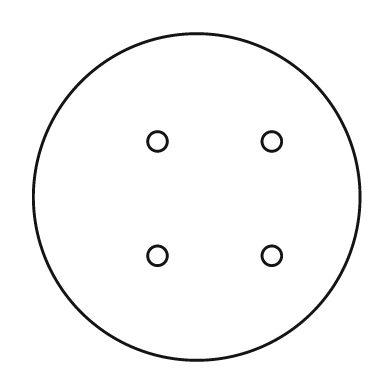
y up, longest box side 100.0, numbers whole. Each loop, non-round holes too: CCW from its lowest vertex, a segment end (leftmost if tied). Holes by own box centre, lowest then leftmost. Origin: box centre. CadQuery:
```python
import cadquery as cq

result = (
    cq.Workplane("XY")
    .moveTo(0.0, 0.0)
    .circle(50.0)
    .moveTo(-12.0, -18.0)
    .circle(3.0)
    .moveTo(23.0, -18.0)
    .circle(3.0)
    .moveTo(-12.0, 17.0)
    .circle(3.0)
    .moveTo(23.0, 17.0)
    .circle(3.0)
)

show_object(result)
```